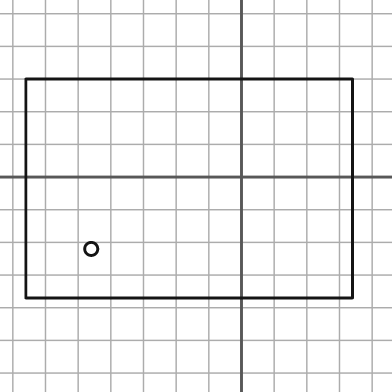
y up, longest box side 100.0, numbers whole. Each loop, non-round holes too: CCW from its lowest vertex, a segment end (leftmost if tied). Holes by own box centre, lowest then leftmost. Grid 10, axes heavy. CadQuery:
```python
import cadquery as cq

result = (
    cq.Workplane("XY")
    .moveTo(-66.0, -37.0)
    .lineTo(34.0, -37.0)
    .lineTo(34.0, 30.0)
    .lineTo(-66.0, 30.0)
    .close()
    .moveTo(-46.0, -22.0)
    .circle(2.0)
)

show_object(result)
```